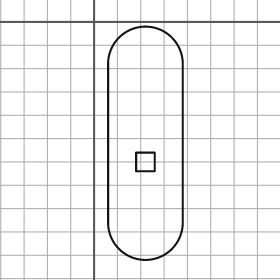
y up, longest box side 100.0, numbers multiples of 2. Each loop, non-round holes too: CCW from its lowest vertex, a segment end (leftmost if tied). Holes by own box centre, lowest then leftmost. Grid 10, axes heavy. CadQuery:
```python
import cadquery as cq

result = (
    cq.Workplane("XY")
    .moveTo(6.0, -86.0)
    .threePointArc((22.0, -102.0), (38.0, -86.0))
    .lineTo(38.0, -18.0)
    .threePointArc((22.0, -2.0), (6.0, -18.0))
    .close()
    .moveTo(18.0, -64.0)
    .lineTo(26.0, -64.0)
    .lineTo(26.0, -56.0)
    .lineTo(18.0, -56.0)
    .close()
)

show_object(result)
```